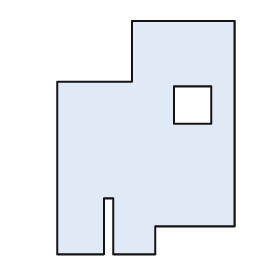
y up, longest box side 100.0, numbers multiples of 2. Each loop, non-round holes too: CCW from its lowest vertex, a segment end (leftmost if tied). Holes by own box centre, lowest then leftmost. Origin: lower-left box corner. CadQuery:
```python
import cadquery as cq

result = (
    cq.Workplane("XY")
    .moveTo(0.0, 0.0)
    .lineTo(20.0, 0.0)
    .lineTo(20.0, 24.0)
    .lineTo(24.0, 24.0)
    .lineTo(24.0, 0.0)
    .lineTo(42.0, 0.0)
    .lineTo(42.0, 12.0)
    .lineTo(76.0, 12.0)
    .lineTo(76.0, 100.0)
    .lineTo(32.0, 100.0)
    .lineTo(32.0, 74.0)
    .lineTo(0.0, 74.0)
    .close()
    .moveTo(50.0, 56.0)
    .lineTo(66.0, 56.0)
    .lineTo(66.0, 72.0)
    .lineTo(50.0, 72.0)
    .close()
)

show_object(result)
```